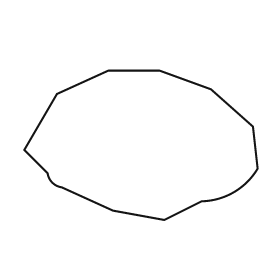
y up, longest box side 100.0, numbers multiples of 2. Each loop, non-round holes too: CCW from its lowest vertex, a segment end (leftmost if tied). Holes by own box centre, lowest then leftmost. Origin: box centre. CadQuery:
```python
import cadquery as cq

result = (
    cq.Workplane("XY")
    .moveTo(10.0, -32.0)
    .lineTo(26.0, -24.0)
    .threePointArc((40.0, -20.0), (50.0, -10.0))
    .lineTo(48.0, 8.0)
    .lineTo(30.0, 24.0)
    .lineTo(8.0, 32.0)
    .lineTo(-14.0, 32.0)
    .lineTo(-36.0, 22.0)
    .lineTo(-50.0, -2.0)
    .lineTo(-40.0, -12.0)
    .threePointArc((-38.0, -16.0), (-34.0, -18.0))
    .lineTo(-12.0, -28.0)
    .close()
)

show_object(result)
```